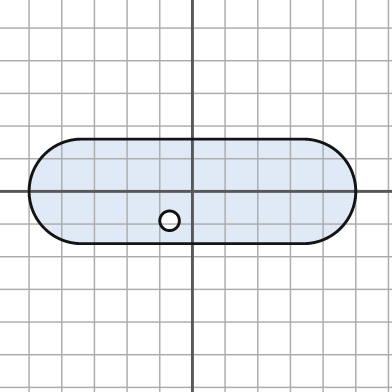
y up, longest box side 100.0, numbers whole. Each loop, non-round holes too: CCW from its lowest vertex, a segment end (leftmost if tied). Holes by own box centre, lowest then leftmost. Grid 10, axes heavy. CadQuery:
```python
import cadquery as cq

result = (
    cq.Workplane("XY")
    .moveTo(-34.0, -16.0)
    .lineTo(34.0, -16.0)
    .threePointArc((50.0, 0.0), (34.0, 16.0))
    .lineTo(-34.0, 16.0)
    .threePointArc((-50.0, 0.0), (-34.0, -16.0))
    .close()
    .moveTo(-7.0, -9.0)
    .circle(3.0)
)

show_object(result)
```